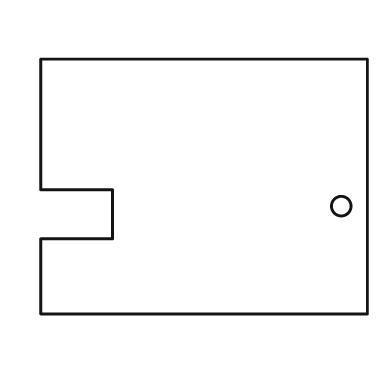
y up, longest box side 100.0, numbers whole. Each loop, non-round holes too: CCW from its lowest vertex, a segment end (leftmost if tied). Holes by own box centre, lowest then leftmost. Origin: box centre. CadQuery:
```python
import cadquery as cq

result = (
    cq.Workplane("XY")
    .moveTo(-50.0, -39.0)
    .lineTo(50.0, -39.0)
    .lineTo(50.0, 39.0)
    .lineTo(-50.0, 39.0)
    .lineTo(-50.0, -1.0)
    .lineTo(-28.0, -1.0)
    .lineTo(-28.0, -16.0)
    .lineTo(-50.0, -16.0)
    .close()
    .moveTo(42.0, -6.0)
    .circle(3.0)
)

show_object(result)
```